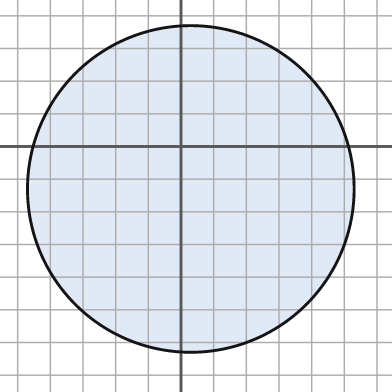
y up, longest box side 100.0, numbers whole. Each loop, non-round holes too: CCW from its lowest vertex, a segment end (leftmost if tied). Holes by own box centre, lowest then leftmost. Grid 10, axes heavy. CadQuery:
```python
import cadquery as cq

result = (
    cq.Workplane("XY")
    .moveTo(3.0, -13.0)
    .circle(50.0)
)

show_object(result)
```